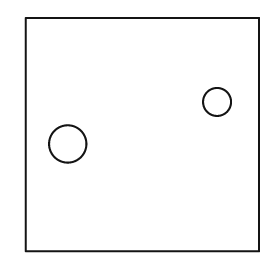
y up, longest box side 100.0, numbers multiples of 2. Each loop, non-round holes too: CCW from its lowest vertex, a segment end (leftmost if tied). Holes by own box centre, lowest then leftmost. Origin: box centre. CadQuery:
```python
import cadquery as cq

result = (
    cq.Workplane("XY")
    .moveTo(-50.0, -50.0)
    .lineTo(50.0, -50.0)
    .lineTo(50.0, 50.0)
    .lineTo(-50.0, 50.0)
    .close()
    .moveTo(-32.0, -4.0)
    .circle(8.0)
    .moveTo(32.0, 14.0)
    .circle(6.0)
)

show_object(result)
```